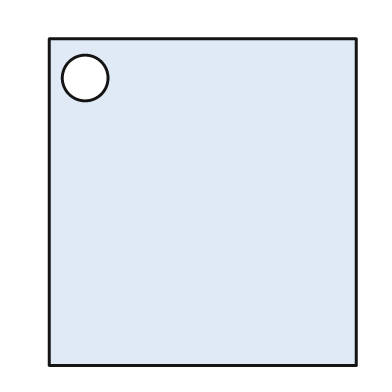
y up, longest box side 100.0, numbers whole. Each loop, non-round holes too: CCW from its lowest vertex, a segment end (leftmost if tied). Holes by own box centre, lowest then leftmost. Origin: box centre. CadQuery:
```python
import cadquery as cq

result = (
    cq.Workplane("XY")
    .moveTo(-47.0, -50.0)
    .lineTo(47.0, -50.0)
    .lineTo(47.0, 50.0)
    .lineTo(-47.0, 50.0)
    .close()
    .moveTo(-36.0, 38.0)
    .circle(7.0)
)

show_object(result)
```